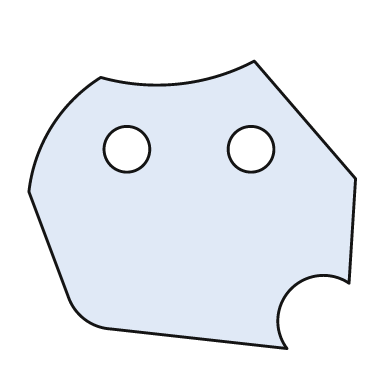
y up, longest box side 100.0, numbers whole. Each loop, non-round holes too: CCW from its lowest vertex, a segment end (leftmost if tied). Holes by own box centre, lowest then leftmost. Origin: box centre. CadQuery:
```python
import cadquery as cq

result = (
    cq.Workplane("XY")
    .moveTo(29.0, -44.0)
    .threePointArc((30.0, -26.0), (48.0, -24.0))
    .lineTo(50.0, 8.0)
    .lineTo(19.0, 44.0)
    .threePointArc((-4.0, 37.0), (-28.0, 39.0))
    .threePointArc((-43.0, 24.0), (-50.0, 4.0))
    .lineTo(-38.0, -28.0)
    .threePointArc((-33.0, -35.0), (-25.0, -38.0))
    .close()
    .moveTo(-20.0, 17.0)
    .circle(7.0)
    .moveTo(18.0, 17.0)
    .circle(7.0)
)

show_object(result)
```